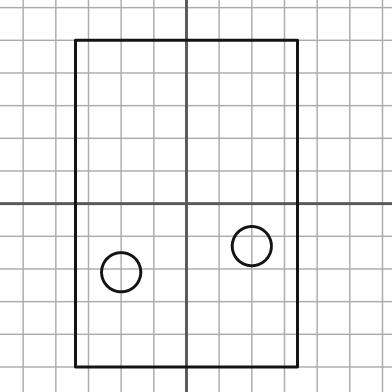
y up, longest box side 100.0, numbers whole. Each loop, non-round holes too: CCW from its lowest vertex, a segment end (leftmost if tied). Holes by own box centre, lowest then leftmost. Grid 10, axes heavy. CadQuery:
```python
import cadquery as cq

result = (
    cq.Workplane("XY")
    .moveTo(-34.0, -50.0)
    .lineTo(34.0, -50.0)
    .lineTo(34.0, 50.0)
    .lineTo(-34.0, 50.0)
    .close()
    .moveTo(-20.0, -21.0)
    .circle(6.0)
    .moveTo(20.0, -13.0)
    .circle(6.0)
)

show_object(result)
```